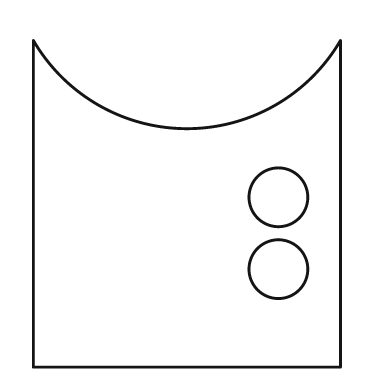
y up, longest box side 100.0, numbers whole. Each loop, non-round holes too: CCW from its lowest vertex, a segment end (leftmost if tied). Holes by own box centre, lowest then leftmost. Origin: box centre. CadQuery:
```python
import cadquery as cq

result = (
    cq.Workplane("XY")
    .moveTo(-47.0, -50.0)
    .lineTo(47.0, -50.0)
    .lineTo(47.0, 50.0)
    .threePointArc((0.0, 23.0), (-47.0, 50.0))
    .close()
    .moveTo(28.0, -20.0)
    .circle(9.0)
    .moveTo(28.0, 2.0)
    .circle(9.0)
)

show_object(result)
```